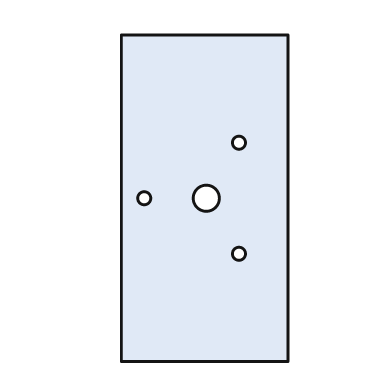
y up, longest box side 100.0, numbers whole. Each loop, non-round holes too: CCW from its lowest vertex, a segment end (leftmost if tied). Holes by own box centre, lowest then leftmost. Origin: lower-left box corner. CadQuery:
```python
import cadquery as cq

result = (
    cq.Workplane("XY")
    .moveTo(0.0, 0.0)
    .lineTo(51.0, 0.0)
    .lineTo(51.0, 100.0)
    .lineTo(0.0, 100.0)
    .close()
    .moveTo(36.0, 33.0)
    .circle(2.0)
    .moveTo(7.0, 50.0)
    .circle(2.0)
    .moveTo(26.0, 50.0)
    .circle(4.0)
    .moveTo(36.0, 67.0)
    .circle(2.0)
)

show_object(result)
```